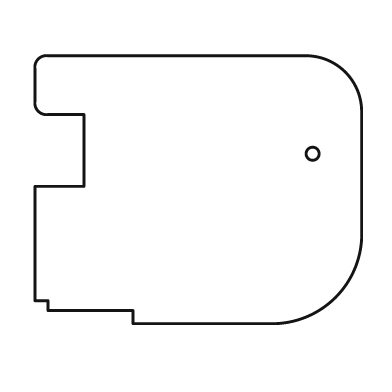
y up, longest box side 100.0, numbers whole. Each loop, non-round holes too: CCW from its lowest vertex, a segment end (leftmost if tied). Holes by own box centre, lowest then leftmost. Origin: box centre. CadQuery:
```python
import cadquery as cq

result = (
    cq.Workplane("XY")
    .moveTo(-20.0, -41.0)
    .lineTo(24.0, -41.0)
    .threePointArc((42.0, -33.0), (50.0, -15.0))
    .lineTo(50.0, 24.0)
    .threePointArc((45.0, 36.0), (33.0, 41.0))
    .lineTo(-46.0, 41.0)
    .threePointArc((-49.0, 40.0), (-50.0, 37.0))
    .lineTo(-50.0, 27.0)
    .threePointArc((-49.0, 24.0), (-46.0, 23.0))
    .lineTo(-35.0, 23.0)
    .lineTo(-35.0, 1.0)
    .lineTo(-50.0, 1.0)
    .lineTo(-50.0, -34.0)
    .lineTo(-46.0, -34.0)
    .lineTo(-46.0, -37.0)
    .lineTo(-20.0, -37.0)
    .close()
    .moveTo(35.0, 11.0)
    .circle(2.0)
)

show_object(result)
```